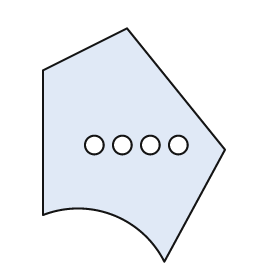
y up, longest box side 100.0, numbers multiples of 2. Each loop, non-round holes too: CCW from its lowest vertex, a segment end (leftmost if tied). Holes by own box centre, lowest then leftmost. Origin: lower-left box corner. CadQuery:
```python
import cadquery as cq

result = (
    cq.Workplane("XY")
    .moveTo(52.0, 0.0)
    .lineTo(78.0, 48.0)
    .lineTo(36.0, 100.0)
    .lineTo(0.0, 82.0)
    .lineTo(0.0, 20.0)
    .threePointArc((30.0, 20.0), (52.0, 0.0))
    .close()
    .moveTo(22.0, 50.0)
    .circle(4.0)
    .moveTo(34.0, 50.0)
    .circle(4.0)
    .moveTo(46.0, 50.0)
    .circle(4.0)
    .moveTo(58.0, 50.0)
    .circle(4.0)
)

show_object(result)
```